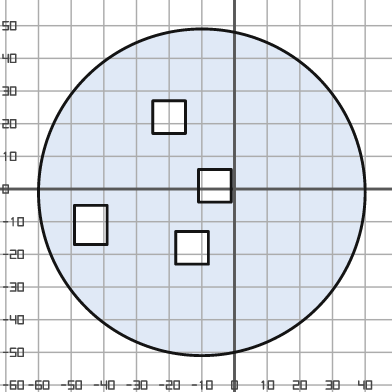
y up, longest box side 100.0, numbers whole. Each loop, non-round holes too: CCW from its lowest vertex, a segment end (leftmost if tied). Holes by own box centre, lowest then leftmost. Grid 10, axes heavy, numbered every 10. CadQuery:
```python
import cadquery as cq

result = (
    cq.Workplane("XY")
    .moveTo(-10.0, -1.0)
    .circle(50.0)
    .moveTo(-18.0, -23.0)
    .lineTo(-8.0, -23.0)
    .lineTo(-8.0, -13.0)
    .lineTo(-18.0, -13.0)
    .close()
    .moveTo(-49.0, -17.0)
    .lineTo(-39.0, -17.0)
    .lineTo(-39.0, -5.0)
    .lineTo(-49.0, -5.0)
    .close()
    .moveTo(-11.0, -4.0)
    .lineTo(-1.0, -4.0)
    .lineTo(-1.0, 6.0)
    .lineTo(-11.0, 6.0)
    .close()
    .moveTo(-25.0, 17.0)
    .lineTo(-15.0, 17.0)
    .lineTo(-15.0, 27.0)
    .lineTo(-25.0, 27.0)
    .close()
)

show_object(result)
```